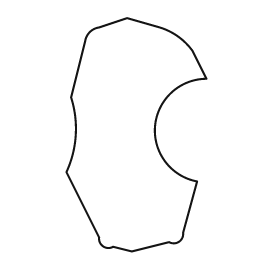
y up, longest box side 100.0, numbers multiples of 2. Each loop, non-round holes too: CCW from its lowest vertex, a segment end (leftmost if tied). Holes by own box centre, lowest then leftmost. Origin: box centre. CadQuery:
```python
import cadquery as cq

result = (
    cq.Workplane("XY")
    .moveTo(-2.0, -50.0)
    .lineTo(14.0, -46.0)
    .threePointArc((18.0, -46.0), (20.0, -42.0))
    .lineTo(26.0, -20.0)
    .threePointArc((8.0, 4.0), (30.0, 24.0))
    .lineTo(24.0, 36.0)
    .threePointArc((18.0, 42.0), (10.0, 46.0))
    .lineTo(-4.0, 50.0)
    .lineTo(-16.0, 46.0)
    .threePointArc((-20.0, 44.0), (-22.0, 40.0))
    .lineTo(-28.0, 16.0)
    .threePointArc((-26.0, 0.0), (-30.0, -16.0))
    .lineTo(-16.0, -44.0)
    .threePointArc((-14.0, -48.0), (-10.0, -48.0))
    .close()
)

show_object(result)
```